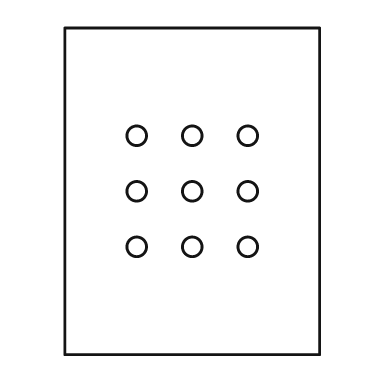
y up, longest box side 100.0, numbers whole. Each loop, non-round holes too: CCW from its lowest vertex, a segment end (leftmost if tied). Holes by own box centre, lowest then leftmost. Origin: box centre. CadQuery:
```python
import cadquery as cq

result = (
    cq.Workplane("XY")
    .moveTo(-39.0, -50.0)
    .lineTo(39.0, -50.0)
    .lineTo(39.0, 50.0)
    .lineTo(-39.0, 50.0)
    .close()
    .moveTo(-17.0, -17.0)
    .circle(3.0)
    .moveTo(0.0, -17.0)
    .circle(3.0)
    .moveTo(17.0, -17.0)
    .circle(3.0)
    .moveTo(-17.0, 0.0)
    .circle(3.0)
    .moveTo(0.0, 0.0)
    .circle(3.0)
    .moveTo(17.0, 0.0)
    .circle(3.0)
    .moveTo(-17.0, 17.0)
    .circle(3.0)
    .moveTo(0.0, 17.0)
    .circle(3.0)
    .moveTo(17.0, 17.0)
    .circle(3.0)
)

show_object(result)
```